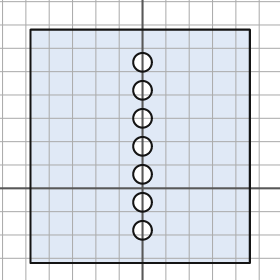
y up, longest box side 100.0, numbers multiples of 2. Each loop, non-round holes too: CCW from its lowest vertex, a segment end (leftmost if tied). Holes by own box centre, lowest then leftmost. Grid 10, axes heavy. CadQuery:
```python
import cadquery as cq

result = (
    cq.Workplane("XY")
    .moveTo(-48.0, -32.0)
    .lineTo(46.0, -32.0)
    .lineTo(46.0, 68.0)
    .lineTo(-48.0, 68.0)
    .close()
    .moveTo(0.0, -18.0)
    .circle(4.0)
    .moveTo(0.0, -6.0)
    .circle(4.0)
    .moveTo(0.0, 6.0)
    .circle(4.0)
    .moveTo(0.0, 18.0)
    .circle(4.0)
    .moveTo(0.0, 30.0)
    .circle(4.0)
    .moveTo(0.0, 42.0)
    .circle(4.0)
    .moveTo(0.0, 54.0)
    .circle(4.0)
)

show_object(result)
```